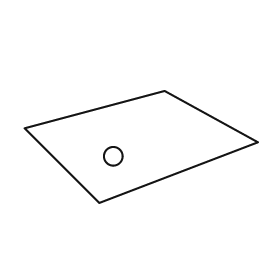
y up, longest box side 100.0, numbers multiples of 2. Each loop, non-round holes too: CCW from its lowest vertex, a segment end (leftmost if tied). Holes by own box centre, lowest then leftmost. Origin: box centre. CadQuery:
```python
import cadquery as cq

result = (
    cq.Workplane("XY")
    .moveTo(-18.0, -24.0)
    .lineTo(50.0, 2.0)
    .lineTo(10.0, 24.0)
    .lineTo(-50.0, 8.0)
    .close()
    .moveTo(-12.0, -4.0)
    .circle(4.0)
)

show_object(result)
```